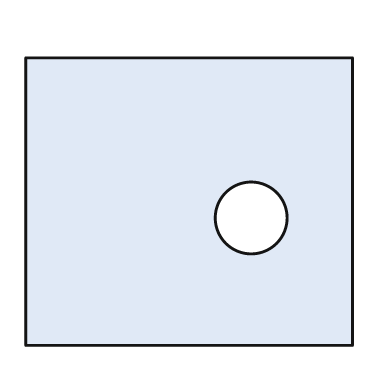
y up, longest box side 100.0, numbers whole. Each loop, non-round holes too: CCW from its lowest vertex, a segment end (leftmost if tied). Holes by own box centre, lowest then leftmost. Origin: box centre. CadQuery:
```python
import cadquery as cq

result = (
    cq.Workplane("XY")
    .moveTo(-50.0, -44.0)
    .lineTo(50.0, -44.0)
    .lineTo(50.0, 44.0)
    .lineTo(-50.0, 44.0)
    .close()
    .moveTo(19.0, -5.0)
    .circle(11.0)
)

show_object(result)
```